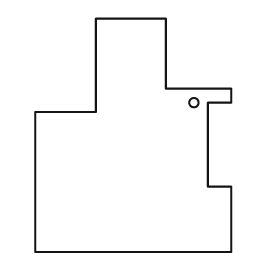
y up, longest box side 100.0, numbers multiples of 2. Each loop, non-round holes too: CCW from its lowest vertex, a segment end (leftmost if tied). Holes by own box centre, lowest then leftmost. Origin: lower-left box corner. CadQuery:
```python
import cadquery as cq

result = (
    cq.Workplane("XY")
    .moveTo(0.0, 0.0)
    .lineTo(84.0, 0.0)
    .lineTo(84.0, 28.0)
    .lineTo(74.0, 28.0)
    .lineTo(74.0, 64.0)
    .lineTo(84.0, 64.0)
    .lineTo(84.0, 70.0)
    .lineTo(56.0, 70.0)
    .lineTo(56.0, 100.0)
    .lineTo(26.0, 100.0)
    .lineTo(26.0, 60.0)
    .lineTo(0.0, 60.0)
    .close()
    .moveTo(68.0, 64.0)
    .circle(2.0)
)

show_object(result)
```